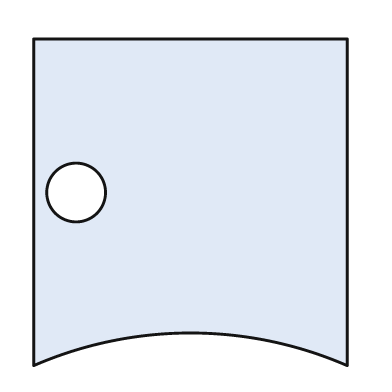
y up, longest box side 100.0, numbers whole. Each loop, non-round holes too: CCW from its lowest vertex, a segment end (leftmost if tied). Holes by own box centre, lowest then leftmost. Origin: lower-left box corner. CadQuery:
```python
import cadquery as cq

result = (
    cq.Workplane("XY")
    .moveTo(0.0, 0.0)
    .threePointArc((48.0, 10.0), (96.0, 0.0))
    .lineTo(96.0, 100.0)
    .lineTo(0.0, 100.0)
    .close()
    .moveTo(13.0, 53.0)
    .circle(9.0)
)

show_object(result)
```